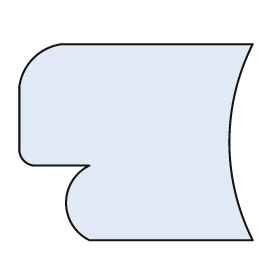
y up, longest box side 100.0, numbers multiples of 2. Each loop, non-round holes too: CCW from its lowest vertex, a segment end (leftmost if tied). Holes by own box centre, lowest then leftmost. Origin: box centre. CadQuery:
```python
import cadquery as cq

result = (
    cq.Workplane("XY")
    .moveTo(-20.0, -42.0)
    .lineTo(50.0, -42.0)
    .threePointArc((40.0, 0.0), (50.0, 42.0))
    .lineTo(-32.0, 42.0)
    .threePointArc((-44.0, 36.0), (-50.0, 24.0))
    .lineTo(-50.0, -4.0)
    .threePointArc((-48.0, -8.0), (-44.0, -10.0))
    .lineTo(-20.0, -10.0)
    .threePointArc((-30.0, -26.0), (-20.0, -42.0))
    .close()
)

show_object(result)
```